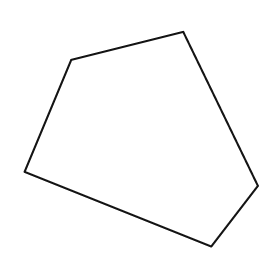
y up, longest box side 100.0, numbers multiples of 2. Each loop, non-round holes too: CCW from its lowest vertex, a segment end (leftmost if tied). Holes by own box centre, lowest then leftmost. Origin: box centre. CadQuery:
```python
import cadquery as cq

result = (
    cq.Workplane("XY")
    .moveTo(30.0, -46.0)
    .lineTo(50.0, -20.0)
    .lineTo(18.0, 46.0)
    .lineTo(-30.0, 34.0)
    .lineTo(-50.0, -14.0)
    .close()
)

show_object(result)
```